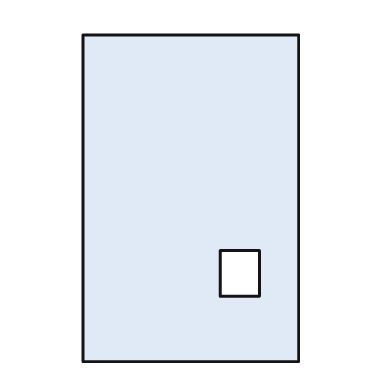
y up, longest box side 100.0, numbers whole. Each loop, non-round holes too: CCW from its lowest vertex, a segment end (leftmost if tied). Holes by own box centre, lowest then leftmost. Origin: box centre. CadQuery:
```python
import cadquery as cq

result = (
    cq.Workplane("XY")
    .moveTo(-33.0, -50.0)
    .lineTo(33.0, -50.0)
    .lineTo(33.0, 50.0)
    .lineTo(-33.0, 50.0)
    .close()
    .moveTo(9.0, -30.0)
    .lineTo(21.0, -30.0)
    .lineTo(21.0, -16.0)
    .lineTo(9.0, -16.0)
    .close()
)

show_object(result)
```